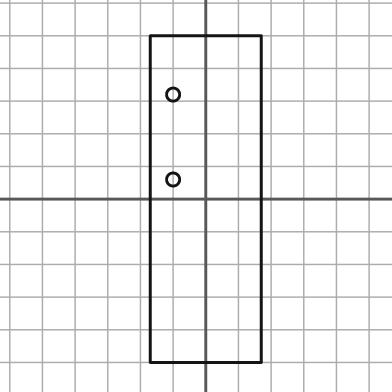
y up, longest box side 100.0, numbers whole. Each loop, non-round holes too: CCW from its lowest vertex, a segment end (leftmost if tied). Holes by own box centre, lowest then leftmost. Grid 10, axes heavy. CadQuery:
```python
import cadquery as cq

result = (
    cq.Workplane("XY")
    .moveTo(-17.0, -50.0)
    .lineTo(17.0, -50.0)
    .lineTo(17.0, 50.0)
    .lineTo(-17.0, 50.0)
    .close()
    .moveTo(-10.0, 6.0)
    .circle(2.0)
    .moveTo(-10.0, 32.0)
    .circle(2.0)
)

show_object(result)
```